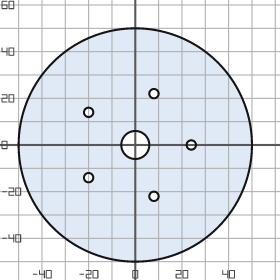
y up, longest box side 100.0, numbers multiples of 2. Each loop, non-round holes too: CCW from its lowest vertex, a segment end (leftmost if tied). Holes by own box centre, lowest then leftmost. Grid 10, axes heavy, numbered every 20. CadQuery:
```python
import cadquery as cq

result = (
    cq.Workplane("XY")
    .moveTo(0.0, 0.0)
    .circle(50.0)
    .moveTo(8.0, -22.0)
    .circle(2.0)
    .moveTo(-20.0, -14.0)
    .circle(2.0)
    .moveTo(0.0, 0.0)
    .circle(6.0)
    .moveTo(24.0, 0.0)
    .circle(2.0)
    .moveTo(-20.0, 14.0)
    .circle(2.0)
    .moveTo(8.0, 22.0)
    .circle(2.0)
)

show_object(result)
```